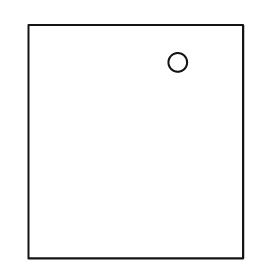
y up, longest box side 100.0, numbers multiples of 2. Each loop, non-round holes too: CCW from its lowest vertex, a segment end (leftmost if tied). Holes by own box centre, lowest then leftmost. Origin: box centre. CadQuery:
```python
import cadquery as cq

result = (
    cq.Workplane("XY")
    .moveTo(-46.0, -50.0)
    .lineTo(46.0, -50.0)
    .lineTo(46.0, 50.0)
    .lineTo(-46.0, 50.0)
    .close()
    .moveTo(18.0, 34.0)
    .circle(4.0)
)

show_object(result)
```